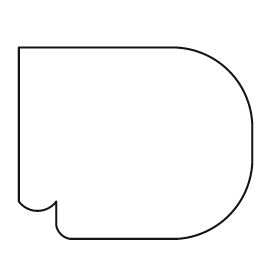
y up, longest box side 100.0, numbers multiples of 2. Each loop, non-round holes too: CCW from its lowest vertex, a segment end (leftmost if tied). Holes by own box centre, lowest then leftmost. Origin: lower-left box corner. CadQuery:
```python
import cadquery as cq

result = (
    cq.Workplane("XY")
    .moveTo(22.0, 0.0)
    .lineTo(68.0, 0.0)
    .threePointArc((90.0, 10.0), (100.0, 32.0))
    .lineTo(100.0, 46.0)
    .threePointArc((90.0, 72.0), (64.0, 82.0))
    .lineTo(0.0, 82.0)
    .lineTo(0.0, 16.0)
    .threePointArc((8.0, 12.0), (16.0, 16.0))
    .lineTo(16.0, 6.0)
    .threePointArc((18.0, 2.0), (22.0, 0.0))
    .close()
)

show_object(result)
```